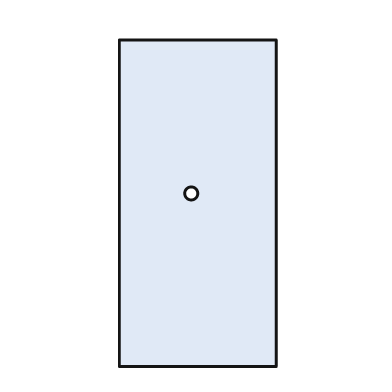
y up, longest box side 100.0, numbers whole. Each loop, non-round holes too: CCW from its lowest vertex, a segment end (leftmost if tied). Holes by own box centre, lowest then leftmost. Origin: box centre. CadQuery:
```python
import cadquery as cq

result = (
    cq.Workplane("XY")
    .moveTo(-24.0, -50.0)
    .lineTo(24.0, -50.0)
    .lineTo(24.0, 50.0)
    .lineTo(-24.0, 50.0)
    .close()
    .moveTo(-2.0, 3.0)
    .circle(2.0)
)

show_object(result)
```